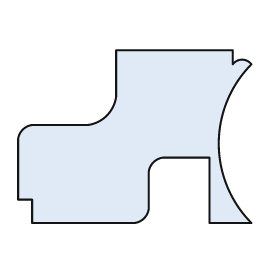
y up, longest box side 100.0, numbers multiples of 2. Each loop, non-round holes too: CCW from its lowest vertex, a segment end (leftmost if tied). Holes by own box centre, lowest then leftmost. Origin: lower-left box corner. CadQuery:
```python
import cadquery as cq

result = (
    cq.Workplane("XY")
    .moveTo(6.0, 0.0)
    .lineTo(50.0, 0.0)
    .threePointArc((54.0, 2.0), (56.0, 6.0))
    .lineTo(56.0, 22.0)
    .threePointArc((58.0, 26.0), (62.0, 28.0))
    .lineTo(82.0, 28.0)
    .lineTo(82.0, 0.0)
    .lineTo(100.0, 0.0)
    .threePointArc((86.0, 34.0), (100.0, 68.0))
    .threePointArc((96.0, 70.0), (92.0, 68.0))
    .lineTo(92.0, 74.0)
    .lineTo(42.0, 74.0)
    .lineTo(42.0, 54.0)
    .threePointArc((38.0, 46.0), (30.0, 42.0))
    .lineTo(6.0, 42.0)
    .threePointArc((2.0, 40.0), (0.0, 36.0))
    .lineTo(0.0, 10.0)
    .lineTo(6.0, 10.0)
    .close()
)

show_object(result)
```